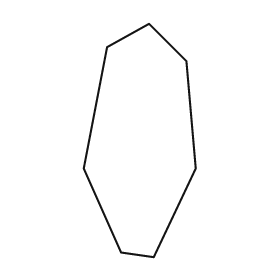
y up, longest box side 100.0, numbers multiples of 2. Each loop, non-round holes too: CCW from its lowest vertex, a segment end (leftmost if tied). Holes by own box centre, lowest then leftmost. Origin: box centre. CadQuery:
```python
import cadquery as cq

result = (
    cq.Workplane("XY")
    .moveTo(6.0, -50.0)
    .lineTo(24.0, -12.0)
    .lineTo(20.0, 34.0)
    .lineTo(4.0, 50.0)
    .lineTo(-14.0, 40.0)
    .lineTo(-24.0, -12.0)
    .lineTo(-8.0, -48.0)
    .close()
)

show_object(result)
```